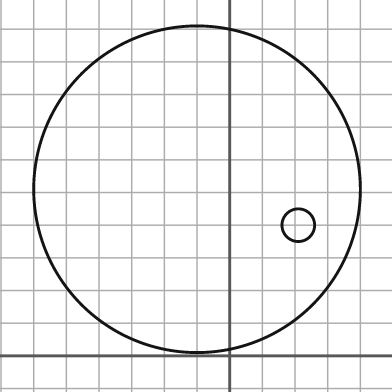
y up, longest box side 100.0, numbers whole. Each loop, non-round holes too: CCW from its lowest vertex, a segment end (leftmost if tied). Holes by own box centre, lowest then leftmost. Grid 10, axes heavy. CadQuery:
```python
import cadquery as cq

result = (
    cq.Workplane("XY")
    .moveTo(-10.0, 51.0)
    .circle(50.0)
    .moveTo(21.0, 40.0)
    .circle(5.0)
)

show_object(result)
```